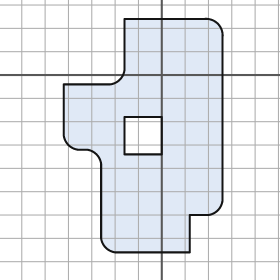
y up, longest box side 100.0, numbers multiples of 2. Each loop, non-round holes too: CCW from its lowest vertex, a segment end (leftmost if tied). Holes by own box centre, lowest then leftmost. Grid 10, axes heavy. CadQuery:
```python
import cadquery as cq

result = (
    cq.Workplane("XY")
    .moveTo(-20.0, -76.0)
    .lineTo(12.0, -76.0)
    .lineTo(12.0, -60.0)
    .lineTo(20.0, -60.0)
    .threePointArc((24.0, -58.0), (26.0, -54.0))
    .lineTo(26.0, 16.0)
    .threePointArc((24.0, 22.0), (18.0, 24.0))
    .lineTo(-16.0, 24.0)
    .lineTo(-16.0, 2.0)
    .threePointArc((-18.0, -2.0), (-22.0, -4.0))
    .lineTo(-42.0, -4.0)
    .lineTo(-42.0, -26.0)
    .threePointArc((-40.0, -30.0), (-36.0, -32.0))
    .lineTo(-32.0, -32.0)
    .threePointArc((-28.0, -34.0), (-26.0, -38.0))
    .lineTo(-26.0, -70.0)
    .threePointArc((-24.0, -74.0), (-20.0, -76.0))
    .close()
    .moveTo(-16.0, -34.0)
    .lineTo(0.0, -34.0)
    .lineTo(0.0, -18.0)
    .lineTo(-16.0, -18.0)
    .close()
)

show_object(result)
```